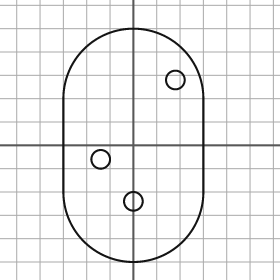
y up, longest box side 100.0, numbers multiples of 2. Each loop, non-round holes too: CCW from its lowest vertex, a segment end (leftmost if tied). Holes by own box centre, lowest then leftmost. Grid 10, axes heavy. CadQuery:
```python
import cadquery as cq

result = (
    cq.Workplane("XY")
    .moveTo(-30.0, -20.0)
    .threePointArc((0.0, -50.0), (30.0, -20.0))
    .lineTo(30.0, 20.0)
    .threePointArc((0.0, 50.0), (-30.0, 20.0))
    .close()
    .moveTo(0.0, -24.0)
    .circle(4.0)
    .moveTo(-14.0, -6.0)
    .circle(4.0)
    .moveTo(18.0, 28.0)
    .circle(4.0)
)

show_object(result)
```